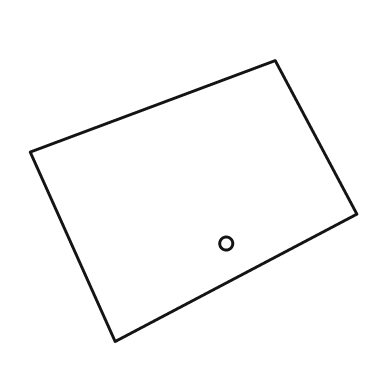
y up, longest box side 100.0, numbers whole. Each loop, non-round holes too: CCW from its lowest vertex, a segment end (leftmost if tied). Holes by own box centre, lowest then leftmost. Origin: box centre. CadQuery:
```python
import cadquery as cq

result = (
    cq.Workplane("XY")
    .moveTo(-24.0, -43.0)
    .lineTo(50.0, -4.0)
    .lineTo(25.0, 43.0)
    .lineTo(-50.0, 15.0)
    .close()
    .moveTo(10.0, -13.0)
    .circle(2.0)
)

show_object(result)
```